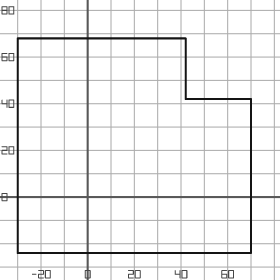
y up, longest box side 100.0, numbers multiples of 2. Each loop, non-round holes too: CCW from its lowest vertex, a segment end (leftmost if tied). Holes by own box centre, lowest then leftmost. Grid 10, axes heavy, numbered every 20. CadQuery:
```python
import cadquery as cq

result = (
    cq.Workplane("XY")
    .moveTo(-30.0, -24.0)
    .lineTo(70.0, -24.0)
    .lineTo(70.0, 42.0)
    .lineTo(42.0, 42.0)
    .lineTo(42.0, 68.0)
    .lineTo(-30.0, 68.0)
    .close()
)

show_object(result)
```